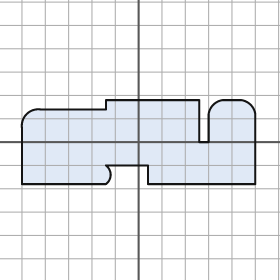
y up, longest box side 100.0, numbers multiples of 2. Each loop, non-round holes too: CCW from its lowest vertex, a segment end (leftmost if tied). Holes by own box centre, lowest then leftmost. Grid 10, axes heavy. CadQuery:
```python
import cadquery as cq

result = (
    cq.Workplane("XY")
    .moveTo(-50.0, -18.0)
    .lineTo(-14.0, -18.0)
    .threePointArc((-12.0, -14.0), (-14.0, -10.0))
    .lineTo(4.0, -10.0)
    .lineTo(4.0, -18.0)
    .lineTo(50.0, -18.0)
    .lineTo(50.0, 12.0)
    .threePointArc((48.0, 16.0), (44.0, 18.0))
    .lineTo(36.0, 18.0)
    .threePointArc((32.0, 16.0), (30.0, 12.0))
    .lineTo(30.0, 0.0)
    .lineTo(26.0, 0.0)
    .lineTo(26.0, 18.0)
    .lineTo(-14.0, 18.0)
    .lineTo(-14.0, 14.0)
    .lineTo(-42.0, 14.0)
    .threePointArc((-48.0, 12.0), (-50.0, 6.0))
    .close()
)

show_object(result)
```